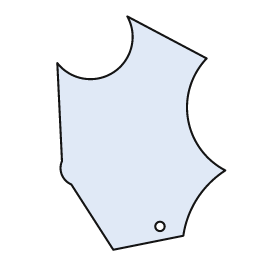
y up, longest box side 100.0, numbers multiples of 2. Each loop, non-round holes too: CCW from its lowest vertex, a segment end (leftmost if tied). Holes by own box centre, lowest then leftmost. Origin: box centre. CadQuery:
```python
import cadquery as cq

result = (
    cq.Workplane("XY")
    .moveTo(-12.0, -50.0)
    .lineTo(18.0, -44.0)
    .threePointArc((24.0, -28.0), (36.0, -16.0))
    .threePointArc((20.0, 6.0), (28.0, 32.0))
    .lineTo(-6.0, 50.0)
    .threePointArc((-12.0, 26.0), (-36.0, 30.0))
    .lineTo(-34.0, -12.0)
    .threePointArc((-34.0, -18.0), (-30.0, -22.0))
    .close()
    .moveTo(8.0, -40.0)
    .circle(2.0)
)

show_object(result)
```